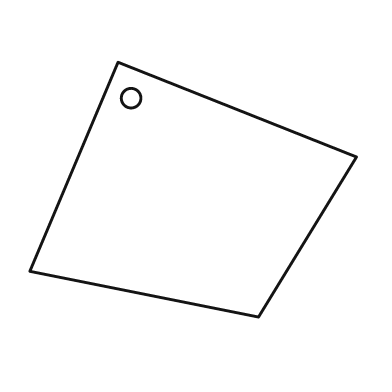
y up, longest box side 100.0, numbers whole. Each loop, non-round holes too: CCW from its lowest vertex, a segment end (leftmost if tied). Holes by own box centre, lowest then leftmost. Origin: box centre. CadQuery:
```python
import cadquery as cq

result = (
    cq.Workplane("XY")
    .moveTo(20.0, -39.0)
    .lineTo(50.0, 10.0)
    .lineTo(-23.0, 39.0)
    .lineTo(-50.0, -25.0)
    .close()
    .moveTo(-19.0, 28.0)
    .circle(3.0)
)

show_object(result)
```